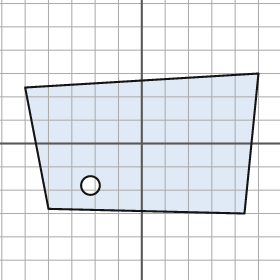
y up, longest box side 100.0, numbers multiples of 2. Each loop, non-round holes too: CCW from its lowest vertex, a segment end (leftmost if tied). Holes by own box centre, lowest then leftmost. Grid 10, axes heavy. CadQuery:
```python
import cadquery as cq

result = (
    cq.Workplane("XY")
    .moveTo(44.0, -30.0)
    .lineTo(50.0, 30.0)
    .lineTo(-50.0, 24.0)
    .lineTo(-40.0, -28.0)
    .close()
    .moveTo(-22.0, -18.0)
    .circle(4.0)
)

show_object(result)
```